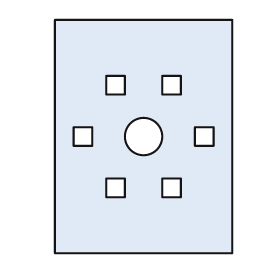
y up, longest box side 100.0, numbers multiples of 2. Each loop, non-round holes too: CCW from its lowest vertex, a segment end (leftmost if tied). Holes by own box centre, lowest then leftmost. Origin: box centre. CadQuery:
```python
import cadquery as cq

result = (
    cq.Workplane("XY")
    .moveTo(-38.0, -50.0)
    .lineTo(38.0, -50.0)
    .lineTo(38.0, 50.0)
    .lineTo(-38.0, 50.0)
    .close()
    .moveTo(-16.0, -26.0)
    .lineTo(-8.0, -26.0)
    .lineTo(-8.0, -18.0)
    .lineTo(-16.0, -18.0)
    .close()
    .moveTo(8.0, -26.0)
    .lineTo(16.0, -26.0)
    .lineTo(16.0, -18.0)
    .lineTo(8.0, -18.0)
    .close()
    .moveTo(-30.0, -4.0)
    .lineTo(-22.0, -4.0)
    .lineTo(-22.0, 4.0)
    .lineTo(-30.0, 4.0)
    .close()
    .moveTo(0.0, 0.0)
    .circle(8.0)
    .moveTo(22.0, -4.0)
    .lineTo(30.0, -4.0)
    .lineTo(30.0, 4.0)
    .lineTo(22.0, 4.0)
    .close()
    .moveTo(-16.0, 18.0)
    .lineTo(-8.0, 18.0)
    .lineTo(-8.0, 26.0)
    .lineTo(-16.0, 26.0)
    .close()
    .moveTo(8.0, 18.0)
    .lineTo(16.0, 18.0)
    .lineTo(16.0, 26.0)
    .lineTo(8.0, 26.0)
    .close()
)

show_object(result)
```